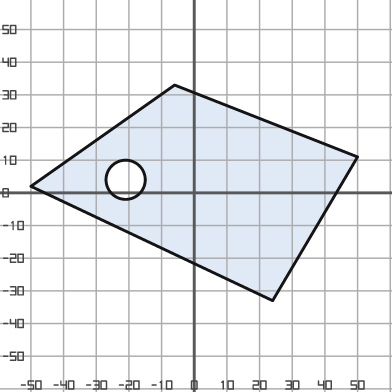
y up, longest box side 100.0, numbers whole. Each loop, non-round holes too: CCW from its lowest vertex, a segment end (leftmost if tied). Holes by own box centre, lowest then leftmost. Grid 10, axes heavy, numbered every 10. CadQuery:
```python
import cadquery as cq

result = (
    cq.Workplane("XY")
    .moveTo(24.0, -33.0)
    .lineTo(50.0, 11.0)
    .lineTo(-6.0, 33.0)
    .lineTo(-50.0, 2.0)
    .close()
    .moveTo(-21.0, 4.0)
    .circle(6.0)
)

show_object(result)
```